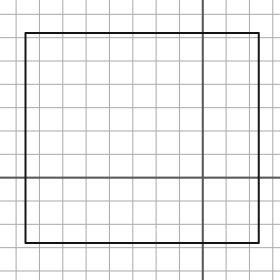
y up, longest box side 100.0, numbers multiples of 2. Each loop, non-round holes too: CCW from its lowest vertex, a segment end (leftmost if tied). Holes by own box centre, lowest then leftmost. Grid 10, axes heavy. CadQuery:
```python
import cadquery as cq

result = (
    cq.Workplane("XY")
    .moveTo(-76.0, -28.0)
    .lineTo(24.0, -28.0)
    .lineTo(24.0, 62.0)
    .lineTo(-76.0, 62.0)
    .close()
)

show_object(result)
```